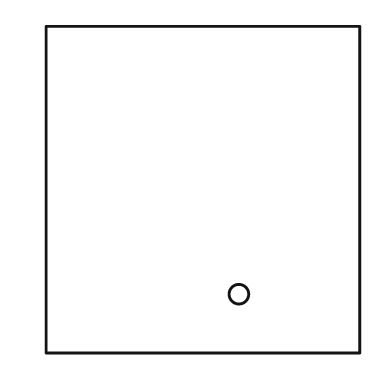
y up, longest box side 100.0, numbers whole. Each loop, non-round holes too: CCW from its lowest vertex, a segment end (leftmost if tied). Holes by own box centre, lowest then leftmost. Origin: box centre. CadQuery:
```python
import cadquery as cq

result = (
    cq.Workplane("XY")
    .moveTo(-48.0, -50.0)
    .lineTo(48.0, -50.0)
    .lineTo(48.0, 50.0)
    .lineTo(-48.0, 50.0)
    .close()
    .moveTo(11.0, -32.0)
    .circle(3.0)
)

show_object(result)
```